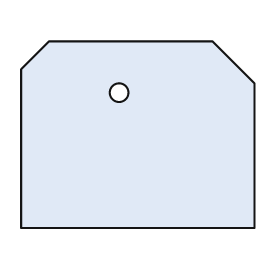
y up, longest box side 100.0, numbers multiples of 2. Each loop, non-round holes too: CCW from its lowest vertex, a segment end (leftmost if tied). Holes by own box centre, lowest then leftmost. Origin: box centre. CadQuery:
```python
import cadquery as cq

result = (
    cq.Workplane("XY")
    .moveTo(-50.0, -40.0)
    .lineTo(50.0, -40.0)
    .lineTo(50.0, 22.0)
    .lineTo(32.0, 40.0)
    .lineTo(-38.0, 40.0)
    .lineTo(-50.0, 28.0)
    .close()
    .moveTo(-8.0, 18.0)
    .circle(4.0)
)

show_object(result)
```